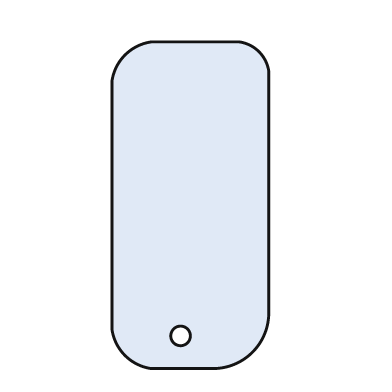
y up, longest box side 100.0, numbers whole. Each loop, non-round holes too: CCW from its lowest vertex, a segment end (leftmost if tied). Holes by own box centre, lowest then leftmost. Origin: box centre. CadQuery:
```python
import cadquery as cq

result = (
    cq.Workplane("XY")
    .moveTo(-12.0, -50.0)
    .lineTo(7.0, -50.0)
    .threePointArc((19.0, -45.0), (24.0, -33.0))
    .lineTo(24.0, 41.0)
    .threePointArc((21.0, 47.0), (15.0, 50.0))
    .lineTo(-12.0, 50.0)
    .threePointArc((-20.0, 46.0), (-24.0, 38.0))
    .lineTo(-24.0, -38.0)
    .threePointArc((-20.0, -46.0), (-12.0, -50.0))
    .close()
    .moveTo(-3.0, -40.0)
    .circle(3.0)
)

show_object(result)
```